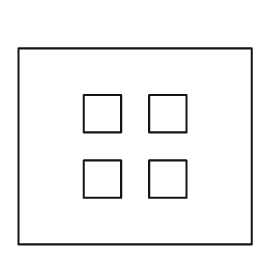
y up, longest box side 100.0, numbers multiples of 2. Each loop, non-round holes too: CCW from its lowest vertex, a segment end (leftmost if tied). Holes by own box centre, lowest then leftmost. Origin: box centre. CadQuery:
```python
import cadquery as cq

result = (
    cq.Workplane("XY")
    .moveTo(-50.0, -42.0)
    .lineTo(50.0, -42.0)
    .lineTo(50.0, 42.0)
    .lineTo(-50.0, 42.0)
    .close()
    .moveTo(-22.0, -22.0)
    .lineTo(-6.0, -22.0)
    .lineTo(-6.0, -6.0)
    .lineTo(-22.0, -6.0)
    .close()
    .moveTo(6.0, -22.0)
    .lineTo(22.0, -22.0)
    .lineTo(22.0, -6.0)
    .lineTo(6.0, -6.0)
    .close()
    .moveTo(-22.0, 6.0)
    .lineTo(-6.0, 6.0)
    .lineTo(-6.0, 22.0)
    .lineTo(-22.0, 22.0)
    .close()
    .moveTo(6.0, 6.0)
    .lineTo(22.0, 6.0)
    .lineTo(22.0, 22.0)
    .lineTo(6.0, 22.0)
    .close()
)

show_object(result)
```